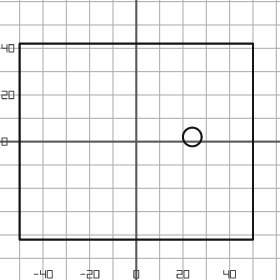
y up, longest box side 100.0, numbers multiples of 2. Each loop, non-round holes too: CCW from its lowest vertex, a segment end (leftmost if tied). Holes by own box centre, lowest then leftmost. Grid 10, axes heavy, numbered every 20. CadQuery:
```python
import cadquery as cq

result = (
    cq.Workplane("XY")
    .moveTo(-50.0, -42.0)
    .lineTo(50.0, -42.0)
    .lineTo(50.0, 42.0)
    .lineTo(-50.0, 42.0)
    .close()
    .moveTo(24.0, 2.0)
    .circle(4.0)
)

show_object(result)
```